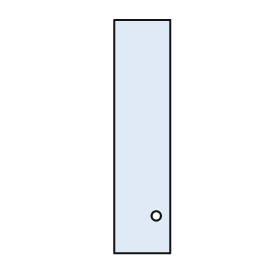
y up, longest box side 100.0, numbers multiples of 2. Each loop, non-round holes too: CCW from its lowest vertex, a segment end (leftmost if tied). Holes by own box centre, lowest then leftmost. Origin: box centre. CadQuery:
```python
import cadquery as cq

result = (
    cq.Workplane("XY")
    .moveTo(-12.0, -50.0)
    .lineTo(12.0, -50.0)
    .lineTo(12.0, 50.0)
    .lineTo(-12.0, 50.0)
    .close()
    .moveTo(6.0, -34.0)
    .circle(2.0)
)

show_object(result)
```